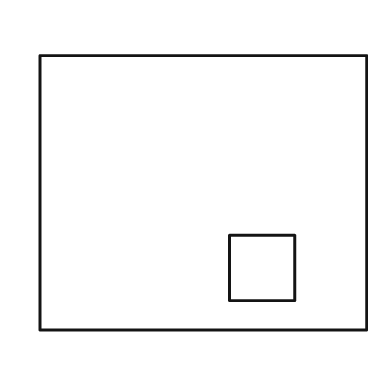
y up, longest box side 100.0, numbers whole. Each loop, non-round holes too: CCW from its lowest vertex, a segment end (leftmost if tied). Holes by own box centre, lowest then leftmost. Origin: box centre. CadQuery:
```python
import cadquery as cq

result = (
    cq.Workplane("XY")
    .moveTo(-50.0, -42.0)
    .lineTo(50.0, -42.0)
    .lineTo(50.0, 42.0)
    .lineTo(-50.0, 42.0)
    .close()
    .moveTo(8.0, -33.0)
    .lineTo(28.0, -33.0)
    .lineTo(28.0, -13.0)
    .lineTo(8.0, -13.0)
    .close()
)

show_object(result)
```